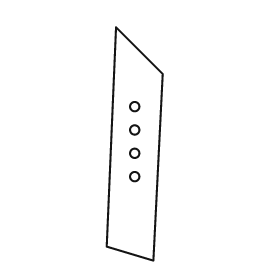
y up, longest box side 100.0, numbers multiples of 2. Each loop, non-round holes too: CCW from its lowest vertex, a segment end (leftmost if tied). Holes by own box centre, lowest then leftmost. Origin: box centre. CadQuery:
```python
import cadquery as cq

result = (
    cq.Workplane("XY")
    .moveTo(8.0, -50.0)
    .lineTo(12.0, 30.0)
    .lineTo(-8.0, 50.0)
    .lineTo(-12.0, -44.0)
    .close()
    .moveTo(0.0, -14.0)
    .circle(2.0)
    .moveTo(0.0, -4.0)
    .circle(2.0)
    .moveTo(0.0, 6.0)
    .circle(2.0)
    .moveTo(0.0, 16.0)
    .circle(2.0)
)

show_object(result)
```